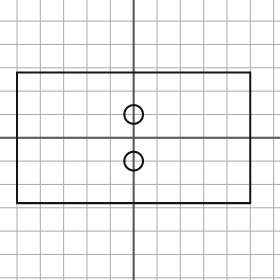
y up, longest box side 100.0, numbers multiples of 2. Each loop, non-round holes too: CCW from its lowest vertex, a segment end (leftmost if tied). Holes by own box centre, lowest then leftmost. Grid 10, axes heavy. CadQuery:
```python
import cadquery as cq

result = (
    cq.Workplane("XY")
    .moveTo(-50.0, -28.0)
    .lineTo(50.0, -28.0)
    .lineTo(50.0, 28.0)
    .lineTo(-50.0, 28.0)
    .close()
    .moveTo(0.0, -10.0)
    .circle(4.0)
    .moveTo(0.0, 10.0)
    .circle(4.0)
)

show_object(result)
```